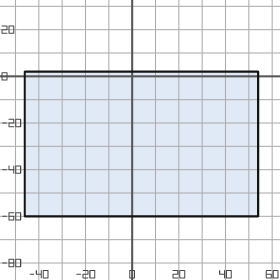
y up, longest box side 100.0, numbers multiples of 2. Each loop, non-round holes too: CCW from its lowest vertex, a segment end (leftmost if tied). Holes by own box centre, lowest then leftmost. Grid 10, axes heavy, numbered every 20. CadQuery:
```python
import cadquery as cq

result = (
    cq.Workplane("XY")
    .moveTo(-46.0, -60.0)
    .lineTo(54.0, -60.0)
    .lineTo(54.0, 2.0)
    .lineTo(-46.0, 2.0)
    .close()
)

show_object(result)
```